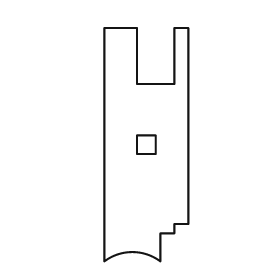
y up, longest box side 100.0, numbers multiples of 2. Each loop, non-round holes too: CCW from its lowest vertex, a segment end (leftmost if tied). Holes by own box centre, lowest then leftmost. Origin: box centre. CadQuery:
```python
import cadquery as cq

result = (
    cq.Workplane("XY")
    .moveTo(-18.0, -50.0)
    .threePointArc((-6.0, -46.0), (6.0, -50.0))
    .lineTo(6.0, -38.0)
    .lineTo(12.0, -38.0)
    .lineTo(12.0, -34.0)
    .lineTo(18.0, -34.0)
    .lineTo(18.0, 50.0)
    .lineTo(12.0, 50.0)
    .lineTo(12.0, 26.0)
    .lineTo(-4.0, 26.0)
    .lineTo(-4.0, 50.0)
    .lineTo(-18.0, 50.0)
    .close()
    .moveTo(-4.0, -4.0)
    .lineTo(4.0, -4.0)
    .lineTo(4.0, 4.0)
    .lineTo(-4.0, 4.0)
    .close()
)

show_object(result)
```